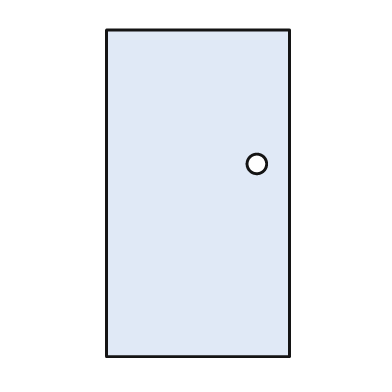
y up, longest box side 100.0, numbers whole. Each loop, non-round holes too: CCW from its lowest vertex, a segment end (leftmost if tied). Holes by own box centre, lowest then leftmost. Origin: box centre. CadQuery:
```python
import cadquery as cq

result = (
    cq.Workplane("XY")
    .moveTo(-28.0, -50.0)
    .lineTo(28.0, -50.0)
    .lineTo(28.0, 50.0)
    .lineTo(-28.0, 50.0)
    .close()
    .moveTo(18.0, 9.0)
    .circle(3.0)
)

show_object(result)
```